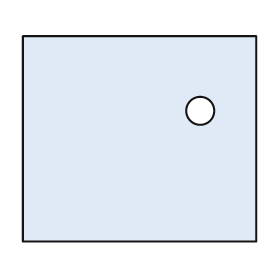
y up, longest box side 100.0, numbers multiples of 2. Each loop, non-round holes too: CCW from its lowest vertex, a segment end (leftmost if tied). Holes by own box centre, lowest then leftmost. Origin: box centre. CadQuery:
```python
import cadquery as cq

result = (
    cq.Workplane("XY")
    .moveTo(-50.0, -44.0)
    .lineTo(50.0, -44.0)
    .lineTo(50.0, 44.0)
    .lineTo(-50.0, 44.0)
    .close()
    .moveTo(26.0, 12.0)
    .circle(6.0)
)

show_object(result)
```